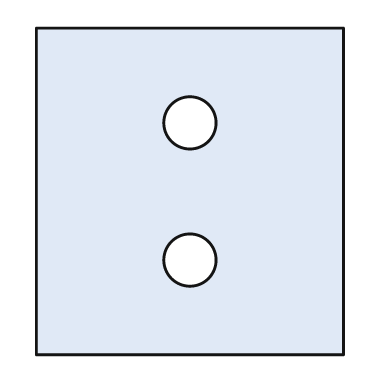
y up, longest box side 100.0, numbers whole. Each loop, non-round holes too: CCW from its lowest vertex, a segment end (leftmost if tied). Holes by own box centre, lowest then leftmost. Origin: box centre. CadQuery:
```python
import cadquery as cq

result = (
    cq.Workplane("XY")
    .moveTo(-47.0, -50.0)
    .lineTo(47.0, -50.0)
    .lineTo(47.0, 50.0)
    .lineTo(-47.0, 50.0)
    .close()
    .moveTo(0.0, -21.0)
    .circle(8.0)
    .moveTo(0.0, 21.0)
    .circle(8.0)
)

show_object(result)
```